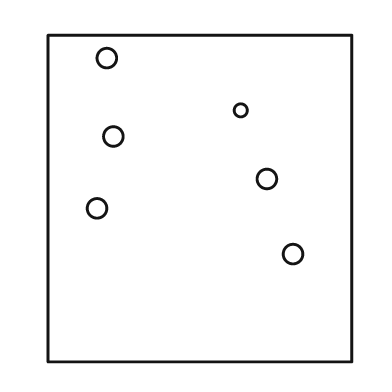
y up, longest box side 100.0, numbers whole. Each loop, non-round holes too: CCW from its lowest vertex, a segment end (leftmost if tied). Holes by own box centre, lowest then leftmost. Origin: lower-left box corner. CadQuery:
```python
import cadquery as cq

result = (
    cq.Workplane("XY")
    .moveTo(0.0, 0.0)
    .lineTo(93.0, 0.0)
    .lineTo(93.0, 100.0)
    .lineTo(0.0, 100.0)
    .close()
    .moveTo(75.0, 33.0)
    .circle(3.0)
    .moveTo(15.0, 47.0)
    .circle(3.0)
    .moveTo(67.0, 56.0)
    .circle(3.0)
    .moveTo(20.0, 69.0)
    .circle(3.0)
    .moveTo(59.0, 77.0)
    .circle(2.0)
    .moveTo(18.0, 93.0)
    .circle(3.0)
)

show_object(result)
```